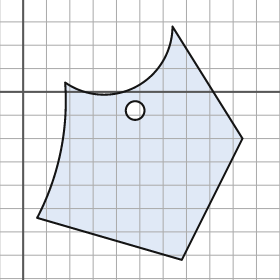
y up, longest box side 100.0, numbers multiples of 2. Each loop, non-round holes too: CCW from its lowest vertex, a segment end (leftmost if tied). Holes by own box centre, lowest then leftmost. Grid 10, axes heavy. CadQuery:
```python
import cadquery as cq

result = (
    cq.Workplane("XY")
    .moveTo(68.0, -72.0)
    .lineTo(94.0, -20.0)
    .lineTo(64.0, 28.0)
    .threePointArc((48.0, 2.0), (18.0, 4.0))
    .threePointArc((16.0, -26.0), (6.0, -54.0))
    .close()
    .moveTo(48.0, -8.0)
    .circle(4.0)
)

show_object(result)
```